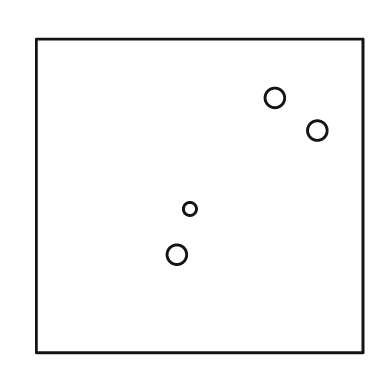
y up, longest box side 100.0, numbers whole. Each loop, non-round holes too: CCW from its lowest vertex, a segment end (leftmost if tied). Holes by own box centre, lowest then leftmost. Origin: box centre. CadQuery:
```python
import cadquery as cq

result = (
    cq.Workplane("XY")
    .moveTo(-50.0, -48.0)
    .lineTo(50.0, -48.0)
    .lineTo(50.0, 48.0)
    .lineTo(-50.0, 48.0)
    .close()
    .moveTo(-7.0, -18.0)
    .circle(3.0)
    .moveTo(-3.0, -4.0)
    .circle(2.0)
    .moveTo(36.0, 20.0)
    .circle(3.0)
    .moveTo(23.0, 30.0)
    .circle(3.0)
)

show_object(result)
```